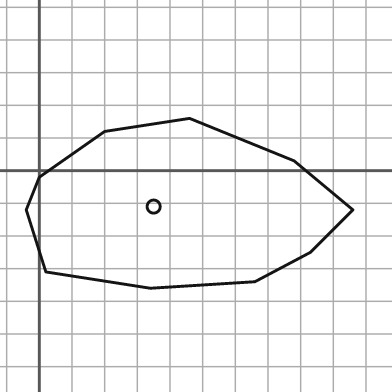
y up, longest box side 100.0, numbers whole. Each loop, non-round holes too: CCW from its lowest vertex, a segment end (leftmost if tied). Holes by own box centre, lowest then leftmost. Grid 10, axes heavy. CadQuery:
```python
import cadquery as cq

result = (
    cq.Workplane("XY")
    .moveTo(34.0, -36.0)
    .lineTo(66.0, -34.0)
    .lineTo(83.0, -25.0)
    .lineTo(96.0, -12.0)
    .lineTo(78.0, 3.0)
    .lineTo(46.0, 16.0)
    .lineTo(20.0, 12.0)
    .lineTo(0.0, -2.0)
    .lineTo(-4.0, -12.0)
    .lineTo(2.0, -31.0)
    .close()
    .moveTo(35.0, -11.0)
    .circle(2.0)
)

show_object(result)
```